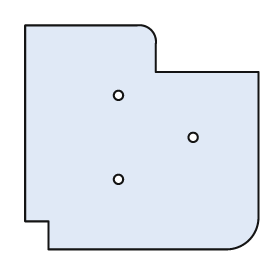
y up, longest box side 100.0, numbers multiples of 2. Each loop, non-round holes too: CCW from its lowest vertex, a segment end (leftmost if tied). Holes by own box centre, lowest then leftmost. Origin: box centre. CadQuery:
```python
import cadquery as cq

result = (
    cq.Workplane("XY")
    .moveTo(-40.0, -48.0)
    .lineTo(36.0, -48.0)
    .threePointArc((46.0, -44.0), (50.0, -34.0))
    .lineTo(50.0, 28.0)
    .lineTo(6.0, 28.0)
    .lineTo(6.0, 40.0)
    .threePointArc((4.0, 46.0), (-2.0, 48.0))
    .lineTo(-50.0, 48.0)
    .lineTo(-50.0, -36.0)
    .lineTo(-40.0, -36.0)
    .close()
    .moveTo(-10.0, -18.0)
    .circle(2.0)
    .moveTo(22.0, 0.0)
    .circle(2.0)
    .moveTo(-10.0, 18.0)
    .circle(2.0)
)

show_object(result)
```